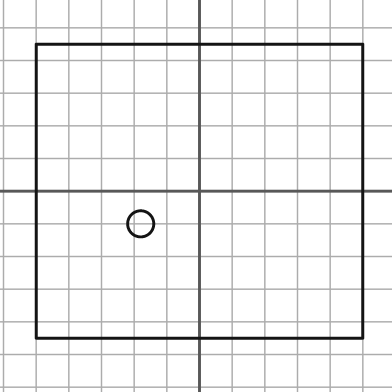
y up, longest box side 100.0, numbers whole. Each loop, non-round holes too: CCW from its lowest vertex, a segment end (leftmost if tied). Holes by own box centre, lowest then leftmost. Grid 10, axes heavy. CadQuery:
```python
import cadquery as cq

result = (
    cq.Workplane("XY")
    .moveTo(-50.0, -45.0)
    .lineTo(50.0, -45.0)
    .lineTo(50.0, 45.0)
    .lineTo(-50.0, 45.0)
    .close()
    .moveTo(-18.0, -10.0)
    .circle(4.0)
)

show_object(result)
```